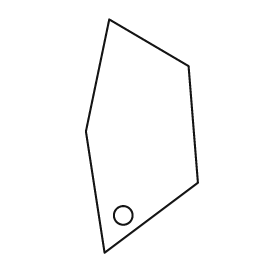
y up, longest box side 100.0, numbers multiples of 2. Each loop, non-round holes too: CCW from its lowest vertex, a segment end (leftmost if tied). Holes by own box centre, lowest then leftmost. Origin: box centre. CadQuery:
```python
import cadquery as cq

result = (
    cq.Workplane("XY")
    .moveTo(-16.0, -50.0)
    .lineTo(24.0, -20.0)
    .lineTo(20.0, 30.0)
    .lineTo(-14.0, 50.0)
    .lineTo(-24.0, 2.0)
    .close()
    .moveTo(-8.0, -34.0)
    .circle(4.0)
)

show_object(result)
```